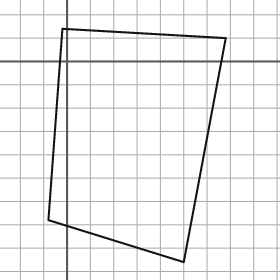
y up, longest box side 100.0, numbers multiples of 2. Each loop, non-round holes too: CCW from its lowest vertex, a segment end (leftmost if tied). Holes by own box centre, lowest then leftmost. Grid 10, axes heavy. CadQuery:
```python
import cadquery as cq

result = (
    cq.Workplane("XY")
    .moveTo(50.0, -86.0)
    .lineTo(68.0, 10.0)
    .lineTo(-2.0, 14.0)
    .lineTo(-8.0, -68.0)
    .close()
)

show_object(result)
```